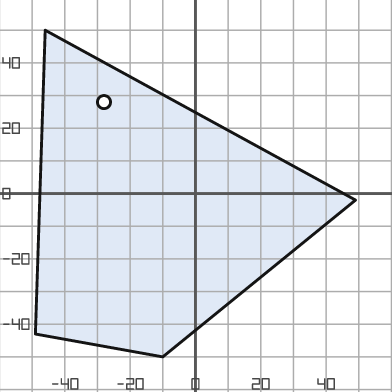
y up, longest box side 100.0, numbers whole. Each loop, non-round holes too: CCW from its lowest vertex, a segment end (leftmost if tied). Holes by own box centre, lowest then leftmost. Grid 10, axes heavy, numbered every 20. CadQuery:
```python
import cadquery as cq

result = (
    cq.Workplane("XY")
    .moveTo(-10.0, -50.0)
    .lineTo(49.0, -2.0)
    .lineTo(-46.0, 50.0)
    .lineTo(-49.0, -43.0)
    .close()
    .moveTo(-28.0, 28.0)
    .circle(2.0)
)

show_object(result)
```